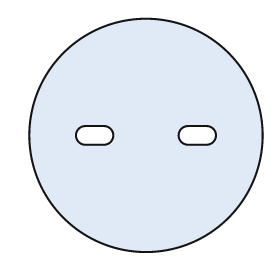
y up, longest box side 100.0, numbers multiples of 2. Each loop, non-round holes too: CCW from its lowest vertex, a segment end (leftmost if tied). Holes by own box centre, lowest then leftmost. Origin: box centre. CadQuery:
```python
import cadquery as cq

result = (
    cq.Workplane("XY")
    .moveTo(0.0, 0.0)
    .circle(50.0)
    .moveTo(-26.0, -4.0)
    .lineTo(-18.0, -4.0)
    .threePointArc((-14.0, 0.0), (-18.0, 4.0))
    .lineTo(-26.0, 4.0)
    .threePointArc((-30.0, 0.0), (-26.0, -4.0))
    .close()
    .moveTo(18.0, -4.0)
    .lineTo(26.0, -4.0)
    .threePointArc((30.0, 0.0), (26.0, 4.0))
    .lineTo(18.0, 4.0)
    .threePointArc((14.0, 0.0), (18.0, -4.0))
    .close()
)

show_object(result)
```